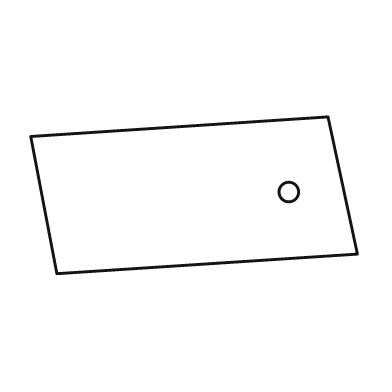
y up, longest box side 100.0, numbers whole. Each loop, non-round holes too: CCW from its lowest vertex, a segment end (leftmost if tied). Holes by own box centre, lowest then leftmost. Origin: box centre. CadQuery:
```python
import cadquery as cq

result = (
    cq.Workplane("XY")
    .moveTo(-42.0, -24.0)
    .lineTo(50.0, -18.0)
    .lineTo(41.0, 24.0)
    .lineTo(-50.0, 18.0)
    .close()
    .moveTo(29.0, 1.0)
    .circle(3.0)
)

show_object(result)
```